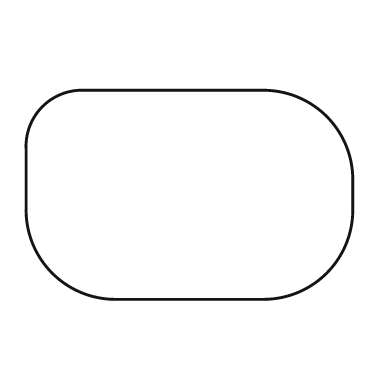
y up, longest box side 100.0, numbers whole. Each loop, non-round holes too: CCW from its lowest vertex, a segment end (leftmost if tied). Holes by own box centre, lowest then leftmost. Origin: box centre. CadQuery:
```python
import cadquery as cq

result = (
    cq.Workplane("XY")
    .moveTo(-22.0, -32.0)
    .lineTo(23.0, -32.0)
    .threePointArc((42.0, -24.0), (50.0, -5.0))
    .lineTo(50.0, 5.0)
    .threePointArc((42.0, 24.0), (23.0, 32.0))
    .lineTo(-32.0, 32.0)
    .threePointArc((-45.0, 27.0), (-50.0, 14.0))
    .lineTo(-50.0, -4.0)
    .threePointArc((-42.0, -24.0), (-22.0, -32.0))
    .close()
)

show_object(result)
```